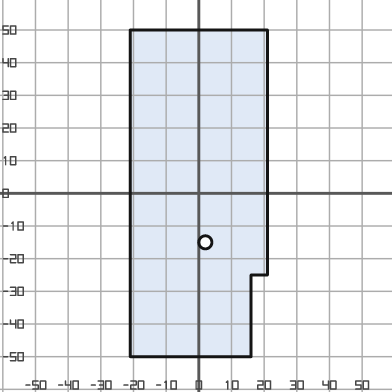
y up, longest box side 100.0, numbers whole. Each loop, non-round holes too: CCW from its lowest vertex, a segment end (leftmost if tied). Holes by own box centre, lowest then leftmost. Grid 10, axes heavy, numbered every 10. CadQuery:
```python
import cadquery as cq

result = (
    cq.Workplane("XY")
    .moveTo(-21.0, -50.0)
    .lineTo(16.0, -50.0)
    .lineTo(16.0, -25.0)
    .lineTo(21.0, -25.0)
    .lineTo(21.0, 50.0)
    .lineTo(-21.0, 50.0)
    .close()
    .moveTo(2.0, -15.0)
    .circle(2.0)
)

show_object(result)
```